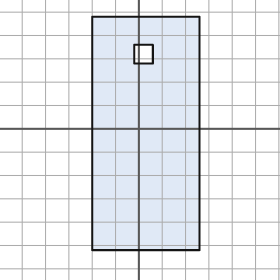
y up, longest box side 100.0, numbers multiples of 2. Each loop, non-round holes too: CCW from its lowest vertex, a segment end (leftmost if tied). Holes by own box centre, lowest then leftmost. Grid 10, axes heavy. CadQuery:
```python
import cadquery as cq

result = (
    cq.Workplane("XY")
    .moveTo(-20.0, -52.0)
    .lineTo(26.0, -52.0)
    .lineTo(26.0, 48.0)
    .lineTo(-20.0, 48.0)
    .close()
    .moveTo(-2.0, 28.0)
    .lineTo(6.0, 28.0)
    .lineTo(6.0, 36.0)
    .lineTo(-2.0, 36.0)
    .close()
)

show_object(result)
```